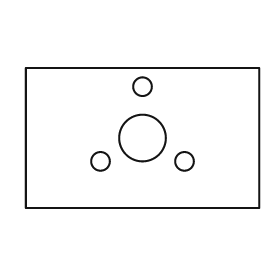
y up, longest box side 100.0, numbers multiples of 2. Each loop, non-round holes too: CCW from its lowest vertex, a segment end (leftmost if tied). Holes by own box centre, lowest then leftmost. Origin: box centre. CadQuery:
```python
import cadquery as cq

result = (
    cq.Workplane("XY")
    .moveTo(-50.0, -30.0)
    .lineTo(50.0, -30.0)
    .lineTo(50.0, 30.0)
    .lineTo(-50.0, 30.0)
    .close()
    .moveTo(-18.0, -10.0)
    .circle(4.0)
    .moveTo(18.0, -10.0)
    .circle(4.0)
    .moveTo(0.0, 0.0)
    .circle(10.0)
    .moveTo(0.0, 22.0)
    .circle(4.0)
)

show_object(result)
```